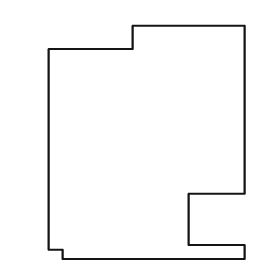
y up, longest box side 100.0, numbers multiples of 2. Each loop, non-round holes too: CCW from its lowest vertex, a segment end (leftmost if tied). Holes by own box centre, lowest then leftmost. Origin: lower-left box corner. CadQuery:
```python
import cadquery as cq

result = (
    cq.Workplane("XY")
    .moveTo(6.0, 0.0)
    .lineTo(84.0, 0.0)
    .lineTo(84.0, 6.0)
    .lineTo(60.0, 6.0)
    .lineTo(60.0, 28.0)
    .lineTo(84.0, 28.0)
    .lineTo(84.0, 100.0)
    .lineTo(36.0, 100.0)
    .lineTo(36.0, 90.0)
    .lineTo(0.0, 90.0)
    .lineTo(0.0, 4.0)
    .lineTo(6.0, 4.0)
    .close()
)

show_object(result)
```